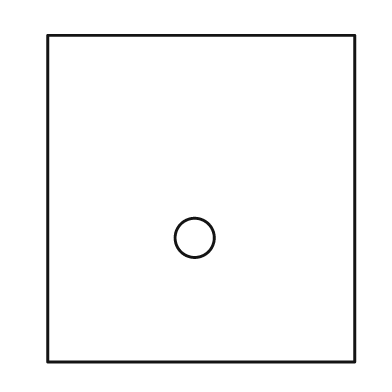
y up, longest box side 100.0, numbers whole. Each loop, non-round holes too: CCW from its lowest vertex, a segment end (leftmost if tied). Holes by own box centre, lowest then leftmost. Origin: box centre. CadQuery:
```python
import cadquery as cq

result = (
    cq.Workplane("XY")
    .moveTo(-47.0, -50.0)
    .lineTo(47.0, -50.0)
    .lineTo(47.0, 50.0)
    .lineTo(-47.0, 50.0)
    .close()
    .moveTo(-2.0, -12.0)
    .circle(6.0)
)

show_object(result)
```